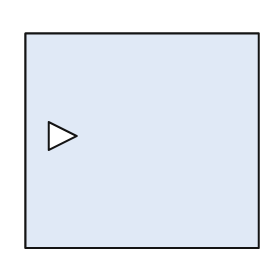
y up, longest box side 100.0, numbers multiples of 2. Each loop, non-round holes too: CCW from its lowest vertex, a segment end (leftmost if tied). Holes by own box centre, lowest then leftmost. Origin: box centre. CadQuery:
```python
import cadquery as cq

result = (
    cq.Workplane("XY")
    .moveTo(-50.0, -46.0)
    .lineTo(50.0, -46.0)
    .lineTo(50.0, 46.0)
    .lineTo(-50.0, 46.0)
    .close()
    .moveTo(-40.0, -4.0)
    .lineTo(-28.0, 2.0)
    .lineTo(-40.0, 8.0)
    .close()
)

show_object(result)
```